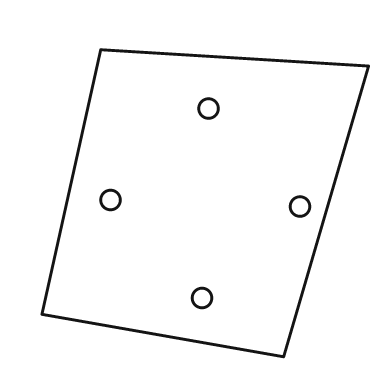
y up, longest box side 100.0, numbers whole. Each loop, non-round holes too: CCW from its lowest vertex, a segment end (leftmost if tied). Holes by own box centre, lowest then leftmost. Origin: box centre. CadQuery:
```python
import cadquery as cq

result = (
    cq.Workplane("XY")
    .moveTo(24.0, -47.0)
    .lineTo(50.0, 42.0)
    .lineTo(-32.0, 47.0)
    .lineTo(-50.0, -34.0)
    .close()
    .moveTo(-1.0, -29.0)
    .circle(3.0)
    .moveTo(29.0, -1.0)
    .circle(3.0)
    .moveTo(-29.0, 1.0)
    .circle(3.0)
    .moveTo(1.0, 29.0)
    .circle(3.0)
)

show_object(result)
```